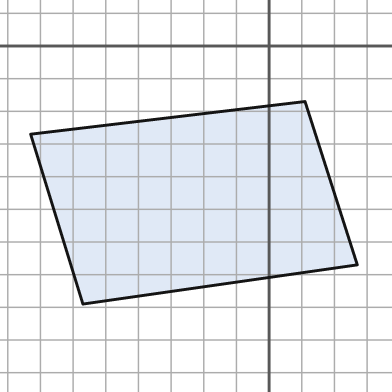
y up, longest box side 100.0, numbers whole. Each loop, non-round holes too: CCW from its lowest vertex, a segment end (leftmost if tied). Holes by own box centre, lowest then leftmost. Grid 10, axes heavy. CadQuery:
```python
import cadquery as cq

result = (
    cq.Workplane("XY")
    .moveTo(-57.0, -79.0)
    .lineTo(27.0, -67.0)
    .lineTo(11.0, -17.0)
    .lineTo(-73.0, -27.0)
    .close()
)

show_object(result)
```